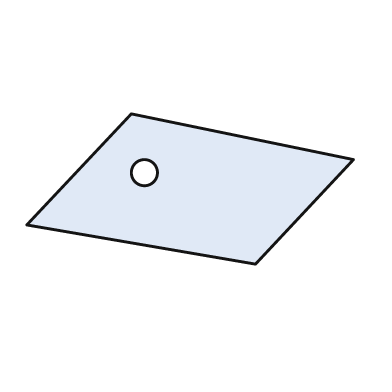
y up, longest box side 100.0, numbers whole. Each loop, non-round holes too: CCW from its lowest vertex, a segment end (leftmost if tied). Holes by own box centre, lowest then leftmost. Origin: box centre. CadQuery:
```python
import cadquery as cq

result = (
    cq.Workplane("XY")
    .moveTo(20.0, -23.0)
    .lineTo(50.0, 9.0)
    .lineTo(-18.0, 23.0)
    .lineTo(-50.0, -11.0)
    .close()
    .moveTo(-14.0, 5.0)
    .circle(4.0)
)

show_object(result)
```